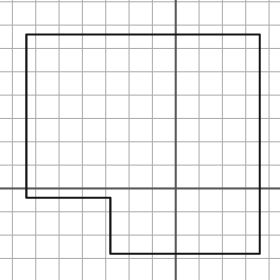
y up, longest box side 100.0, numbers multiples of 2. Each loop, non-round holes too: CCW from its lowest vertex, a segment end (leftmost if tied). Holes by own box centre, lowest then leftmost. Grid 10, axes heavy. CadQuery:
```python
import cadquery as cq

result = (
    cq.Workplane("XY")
    .moveTo(-28.0, -28.0)
    .lineTo(36.0, -28.0)
    .lineTo(36.0, 66.0)
    .lineTo(-64.0, 66.0)
    .lineTo(-64.0, -4.0)
    .lineTo(-28.0, -4.0)
    .close()
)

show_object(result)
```